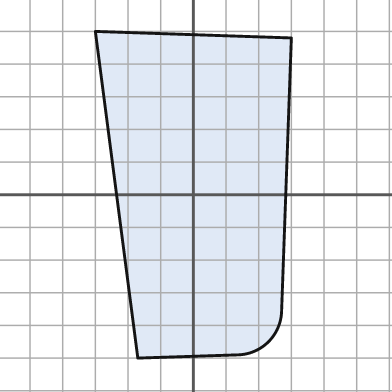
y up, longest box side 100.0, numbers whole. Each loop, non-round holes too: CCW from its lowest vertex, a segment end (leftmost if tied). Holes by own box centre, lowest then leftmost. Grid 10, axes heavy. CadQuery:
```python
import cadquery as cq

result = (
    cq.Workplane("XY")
    .moveTo(-17.0, -50.0)
    .lineTo(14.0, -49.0)
    .threePointArc((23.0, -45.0), (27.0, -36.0))
    .lineTo(30.0, 48.0)
    .lineTo(-30.0, 50.0)
    .close()
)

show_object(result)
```